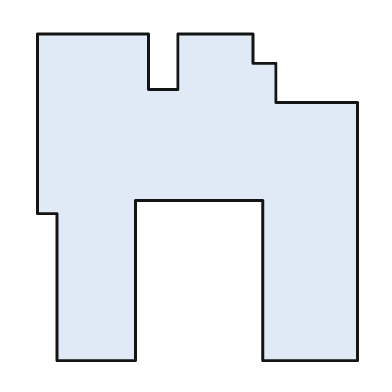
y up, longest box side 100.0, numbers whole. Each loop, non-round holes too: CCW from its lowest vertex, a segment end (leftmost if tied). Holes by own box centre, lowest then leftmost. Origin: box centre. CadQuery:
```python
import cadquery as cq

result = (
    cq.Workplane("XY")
    .moveTo(-43.0, -50.0)
    .lineTo(-19.0, -50.0)
    .lineTo(-19.0, -1.0)
    .lineTo(20.0, -1.0)
    .lineTo(20.0, -50.0)
    .lineTo(49.0, -50.0)
    .lineTo(49.0, 29.0)
    .lineTo(24.0, 29.0)
    .lineTo(24.0, 41.0)
    .lineTo(17.0, 41.0)
    .lineTo(17.0, 50.0)
    .lineTo(-6.0, 50.0)
    .lineTo(-6.0, 33.0)
    .lineTo(-15.0, 33.0)
    .lineTo(-15.0, 50.0)
    .lineTo(-49.0, 50.0)
    .lineTo(-49.0, -5.0)
    .lineTo(-43.0, -5.0)
    .close()
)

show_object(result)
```